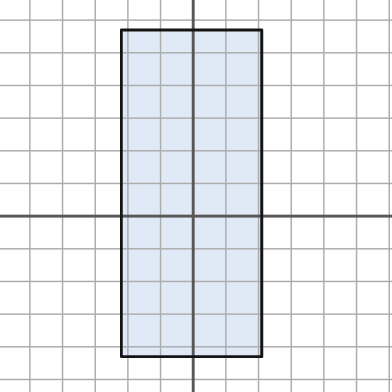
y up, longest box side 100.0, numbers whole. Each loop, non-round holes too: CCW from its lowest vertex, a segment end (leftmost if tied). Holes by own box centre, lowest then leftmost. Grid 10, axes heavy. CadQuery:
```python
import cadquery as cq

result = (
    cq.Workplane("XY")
    .moveTo(-22.0, -43.0)
    .lineTo(21.0, -43.0)
    .lineTo(21.0, 57.0)
    .lineTo(-22.0, 57.0)
    .close()
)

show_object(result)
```